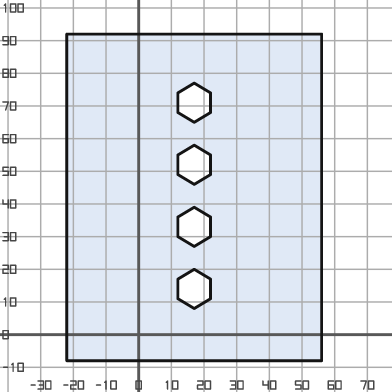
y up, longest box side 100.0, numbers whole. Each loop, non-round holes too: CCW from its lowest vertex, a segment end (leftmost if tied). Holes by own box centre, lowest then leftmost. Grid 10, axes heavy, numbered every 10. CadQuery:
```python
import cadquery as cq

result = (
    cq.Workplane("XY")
    .moveTo(-22.0, -8.0)
    .lineTo(56.0, -8.0)
    .lineTo(56.0, 92.0)
    .lineTo(-22.0, 92.0)
    .close()
    .moveTo(17.0, 8.0)
    .lineTo(22.0, 11.0)
    .lineTo(22.0, 17.0)
    .lineTo(17.0, 20.0)
    .lineTo(12.0, 17.0)
    .lineTo(12.0, 11.0)
    .close()
    .moveTo(17.0, 27.0)
    .lineTo(22.0, 30.0)
    .lineTo(22.0, 36.0)
    .lineTo(17.0, 39.0)
    .lineTo(12.0, 36.0)
    .lineTo(12.0, 30.0)
    .close()
    .moveTo(17.0, 46.0)
    .lineTo(22.0, 49.0)
    .lineTo(22.0, 55.0)
    .lineTo(17.0, 58.0)
    .lineTo(12.0, 55.0)
    .lineTo(12.0, 49.0)
    .close()
    .moveTo(17.0, 65.0)
    .lineTo(22.0, 68.0)
    .lineTo(22.0, 74.0)
    .lineTo(17.0, 77.0)
    .lineTo(12.0, 74.0)
    .lineTo(12.0, 68.0)
    .close()
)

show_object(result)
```